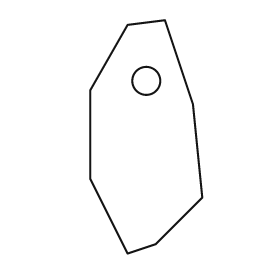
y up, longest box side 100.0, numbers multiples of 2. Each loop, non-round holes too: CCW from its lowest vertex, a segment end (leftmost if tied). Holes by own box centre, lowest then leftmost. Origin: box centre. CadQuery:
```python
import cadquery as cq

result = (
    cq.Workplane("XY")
    .moveTo(-8.0, -50.0)
    .lineTo(4.0, -46.0)
    .lineTo(24.0, -26.0)
    .lineTo(20.0, 14.0)
    .lineTo(8.0, 50.0)
    .lineTo(-8.0, 48.0)
    .lineTo(-24.0, 20.0)
    .lineTo(-24.0, -18.0)
    .close()
    .moveTo(0.0, 24.0)
    .circle(6.0)
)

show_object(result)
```